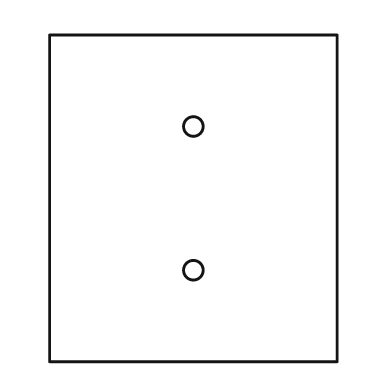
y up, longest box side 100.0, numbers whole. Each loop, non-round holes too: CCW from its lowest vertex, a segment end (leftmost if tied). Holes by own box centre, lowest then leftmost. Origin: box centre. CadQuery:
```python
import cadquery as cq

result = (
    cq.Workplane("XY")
    .moveTo(-44.0, -50.0)
    .lineTo(44.0, -50.0)
    .lineTo(44.0, 50.0)
    .lineTo(-44.0, 50.0)
    .close()
    .moveTo(0.0, -22.0)
    .circle(3.0)
    .moveTo(0.0, 22.0)
    .circle(3.0)
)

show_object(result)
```